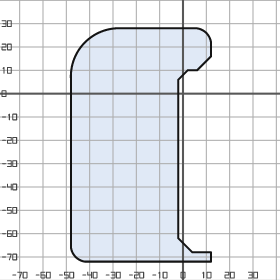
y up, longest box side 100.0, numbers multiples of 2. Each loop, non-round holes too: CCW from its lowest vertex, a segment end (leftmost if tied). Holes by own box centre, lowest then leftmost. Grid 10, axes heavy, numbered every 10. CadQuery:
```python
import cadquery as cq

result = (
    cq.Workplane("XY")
    .moveTo(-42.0, -72.0)
    .lineTo(12.0, -72.0)
    .lineTo(12.0, -68.0)
    .lineTo(4.0, -68.0)
    .lineTo(-2.0, -62.0)
    .lineTo(-2.0, 6.0)
    .lineTo(2.0, 10.0)
    .lineTo(6.0, 10.0)
    .lineTo(12.0, 16.0)
    .lineTo(12.0, 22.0)
    .threePointArc((10.0, 26.0), (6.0, 28.0))
    .lineTo(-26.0, 28.0)
    .threePointArc((-42.0, 22.0), (-48.0, 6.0))
    .lineTo(-48.0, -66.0)
    .threePointArc((-46.0, -70.0), (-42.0, -72.0))
    .close()
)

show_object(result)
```